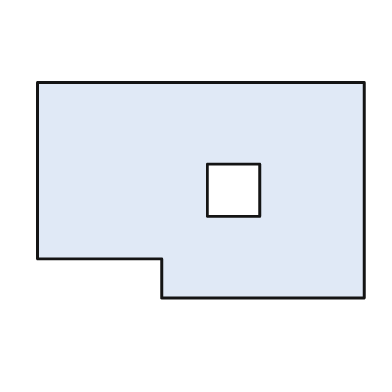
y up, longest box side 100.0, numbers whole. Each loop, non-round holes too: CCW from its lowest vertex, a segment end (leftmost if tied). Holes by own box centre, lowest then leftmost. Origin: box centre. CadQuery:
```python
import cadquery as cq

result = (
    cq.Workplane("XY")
    .moveTo(-12.0, -33.0)
    .lineTo(50.0, -33.0)
    .lineTo(50.0, 33.0)
    .lineTo(-50.0, 33.0)
    .lineTo(-50.0, -21.0)
    .lineTo(-12.0, -21.0)
    .close()
    .moveTo(2.0, -8.0)
    .lineTo(18.0, -8.0)
    .lineTo(18.0, 8.0)
    .lineTo(2.0, 8.0)
    .close()
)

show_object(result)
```